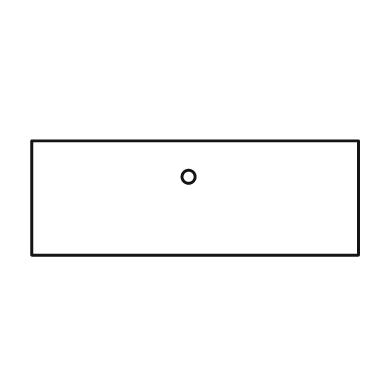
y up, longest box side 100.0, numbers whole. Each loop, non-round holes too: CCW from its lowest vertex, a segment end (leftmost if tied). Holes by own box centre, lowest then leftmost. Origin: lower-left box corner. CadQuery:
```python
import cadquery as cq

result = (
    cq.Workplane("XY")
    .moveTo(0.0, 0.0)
    .lineTo(100.0, 0.0)
    .lineTo(100.0, 35.0)
    .lineTo(0.0, 35.0)
    .close()
    .moveTo(48.0, 24.0)
    .circle(2.0)
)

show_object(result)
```